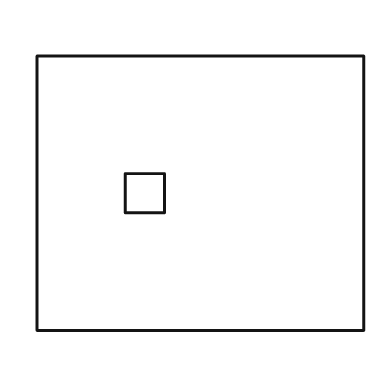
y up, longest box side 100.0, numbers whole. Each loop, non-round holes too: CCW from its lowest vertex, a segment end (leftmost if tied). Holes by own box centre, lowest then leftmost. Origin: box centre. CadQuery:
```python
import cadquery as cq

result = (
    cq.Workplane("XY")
    .moveTo(-50.0, -42.0)
    .lineTo(50.0, -42.0)
    .lineTo(50.0, 42.0)
    .lineTo(-50.0, 42.0)
    .close()
    .moveTo(-23.0, -6.0)
    .lineTo(-11.0, -6.0)
    .lineTo(-11.0, 6.0)
    .lineTo(-23.0, 6.0)
    .close()
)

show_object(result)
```